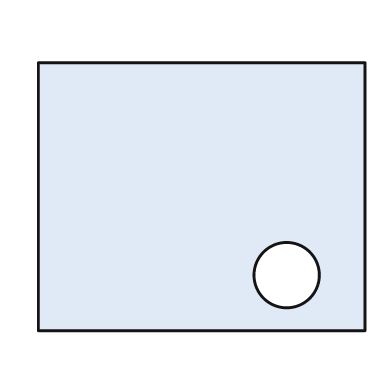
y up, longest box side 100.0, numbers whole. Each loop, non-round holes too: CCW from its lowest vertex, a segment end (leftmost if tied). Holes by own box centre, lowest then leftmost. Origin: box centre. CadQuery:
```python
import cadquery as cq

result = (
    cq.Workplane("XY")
    .moveTo(-50.0, -41.0)
    .lineTo(50.0, -41.0)
    .lineTo(50.0, 41.0)
    .lineTo(-50.0, 41.0)
    .close()
    .moveTo(26.0, -24.0)
    .circle(10.0)
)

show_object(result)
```